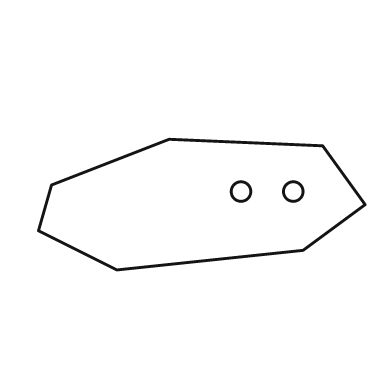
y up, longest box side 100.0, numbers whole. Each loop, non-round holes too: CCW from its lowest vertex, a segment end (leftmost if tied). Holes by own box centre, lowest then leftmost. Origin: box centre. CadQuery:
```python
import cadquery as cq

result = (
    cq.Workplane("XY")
    .moveTo(-26.0, -20.0)
    .lineTo(31.0, -14.0)
    .lineTo(50.0, 0.0)
    .lineTo(37.0, 18.0)
    .lineTo(-10.0, 20.0)
    .lineTo(-46.0, 6.0)
    .lineTo(-50.0, -8.0)
    .close()
    .moveTo(12.0, 4.0)
    .circle(3.0)
    .moveTo(28.0, 4.0)
    .circle(3.0)
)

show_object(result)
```